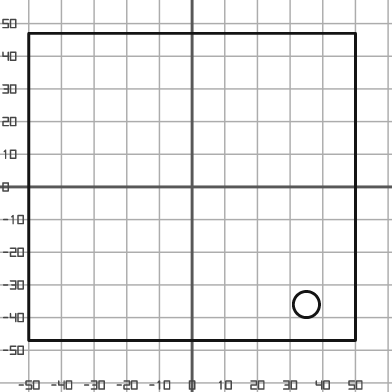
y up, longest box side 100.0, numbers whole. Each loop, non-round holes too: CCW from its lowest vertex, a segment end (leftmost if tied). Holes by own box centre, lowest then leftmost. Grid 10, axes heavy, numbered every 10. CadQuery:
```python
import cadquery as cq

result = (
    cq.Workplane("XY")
    .moveTo(-50.0, -47.0)
    .lineTo(50.0, -47.0)
    .lineTo(50.0, 47.0)
    .lineTo(-50.0, 47.0)
    .close()
    .moveTo(35.0, -36.0)
    .circle(4.0)
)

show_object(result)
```